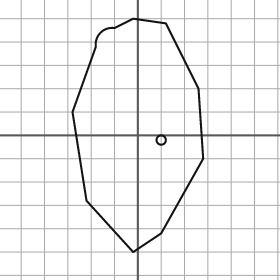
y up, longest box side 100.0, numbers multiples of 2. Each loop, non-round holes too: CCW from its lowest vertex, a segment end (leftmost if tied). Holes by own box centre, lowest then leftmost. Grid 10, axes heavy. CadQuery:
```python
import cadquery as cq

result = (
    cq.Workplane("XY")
    .moveTo(-2.0, -50.0)
    .lineTo(10.0, -42.0)
    .lineTo(28.0, -10.0)
    .lineTo(26.0, 20.0)
    .lineTo(12.0, 48.0)
    .lineTo(-2.0, 50.0)
    .lineTo(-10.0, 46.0)
    .threePointArc((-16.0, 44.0), (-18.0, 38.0))
    .lineTo(-28.0, 10.0)
    .lineTo(-22.0, -28.0)
    .close()
    .moveTo(10.0, -2.0)
    .circle(2.0)
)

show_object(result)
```